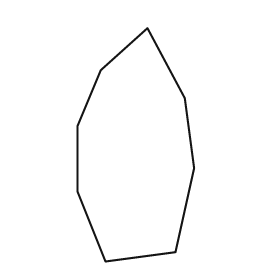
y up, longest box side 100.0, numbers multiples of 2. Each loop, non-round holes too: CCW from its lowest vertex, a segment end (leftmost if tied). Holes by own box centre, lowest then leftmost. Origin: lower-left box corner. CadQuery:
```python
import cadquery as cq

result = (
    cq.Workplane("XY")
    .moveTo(12.0, 0.0)
    .lineTo(42.0, 4.0)
    .lineTo(50.0, 40.0)
    .lineTo(46.0, 70.0)
    .lineTo(30.0, 100.0)
    .lineTo(10.0, 82.0)
    .lineTo(0.0, 58.0)
    .lineTo(0.0, 30.0)
    .close()
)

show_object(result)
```